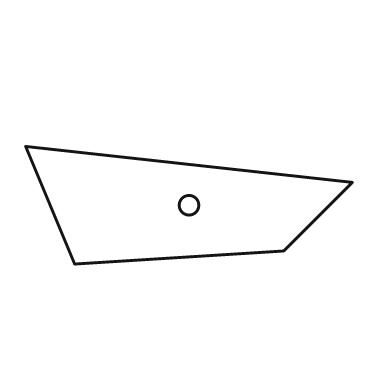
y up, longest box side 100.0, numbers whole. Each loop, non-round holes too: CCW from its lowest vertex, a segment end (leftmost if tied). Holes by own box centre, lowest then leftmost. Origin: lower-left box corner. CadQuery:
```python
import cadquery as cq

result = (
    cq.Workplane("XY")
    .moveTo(15.0, 0.0)
    .lineTo(79.0, 4.0)
    .lineTo(100.0, 25.0)
    .lineTo(0.0, 36.0)
    .close()
    .moveTo(50.0, 18.0)
    .circle(3.0)
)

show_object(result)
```